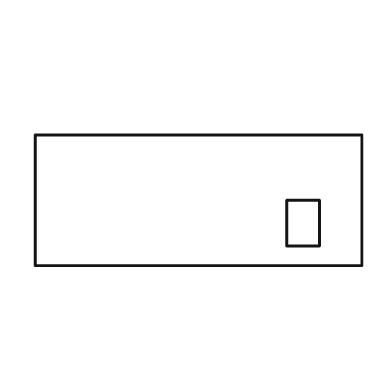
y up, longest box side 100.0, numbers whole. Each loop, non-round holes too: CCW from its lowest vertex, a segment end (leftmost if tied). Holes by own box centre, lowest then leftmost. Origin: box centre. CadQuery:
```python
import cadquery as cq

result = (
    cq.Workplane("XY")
    .moveTo(-50.0, -20.0)
    .lineTo(50.0, -20.0)
    .lineTo(50.0, 20.0)
    .lineTo(-50.0, 20.0)
    .close()
    .moveTo(27.0, -14.0)
    .lineTo(37.0, -14.0)
    .lineTo(37.0, 0.0)
    .lineTo(27.0, 0.0)
    .close()
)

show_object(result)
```